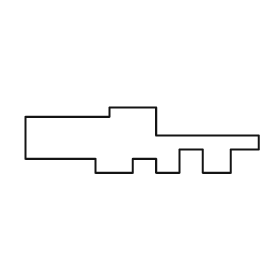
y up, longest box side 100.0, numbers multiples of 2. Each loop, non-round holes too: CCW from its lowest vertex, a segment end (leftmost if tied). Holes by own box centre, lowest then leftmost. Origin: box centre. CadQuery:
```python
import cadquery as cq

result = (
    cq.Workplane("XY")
    .moveTo(-20.0, -14.0)
    .lineTo(-4.0, -14.0)
    .lineTo(-4.0, -8.0)
    .lineTo(6.0, -8.0)
    .lineTo(6.0, -14.0)
    .lineTo(16.0, -14.0)
    .lineTo(16.0, -4.0)
    .lineTo(26.0, -4.0)
    .lineTo(26.0, -14.0)
    .lineTo(38.0, -14.0)
    .lineTo(38.0, -4.0)
    .lineTo(50.0, -4.0)
    .lineTo(50.0, 2.0)
    .lineTo(6.0, 2.0)
    .lineTo(6.0, 14.0)
    .lineTo(-14.0, 14.0)
    .lineTo(-14.0, 10.0)
    .lineTo(-50.0, 10.0)
    .lineTo(-50.0, -8.0)
    .lineTo(-20.0, -8.0)
    .close()
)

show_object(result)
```